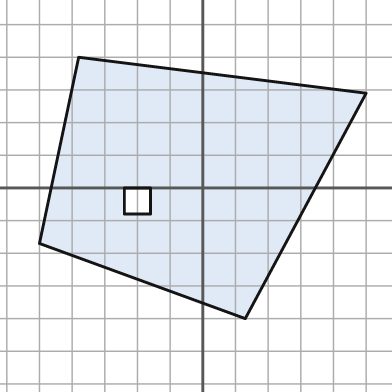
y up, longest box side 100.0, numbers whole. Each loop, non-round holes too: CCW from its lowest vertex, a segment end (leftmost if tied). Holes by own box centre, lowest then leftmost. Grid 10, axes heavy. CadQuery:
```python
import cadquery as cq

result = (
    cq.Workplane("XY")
    .moveTo(13.0, -40.0)
    .lineTo(50.0, 29.0)
    .lineTo(-38.0, 40.0)
    .lineTo(-50.0, -17.0)
    .close()
    .moveTo(-24.0, -8.0)
    .lineTo(-16.0, -8.0)
    .lineTo(-16.0, 0.0)
    .lineTo(-24.0, 0.0)
    .close()
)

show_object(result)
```